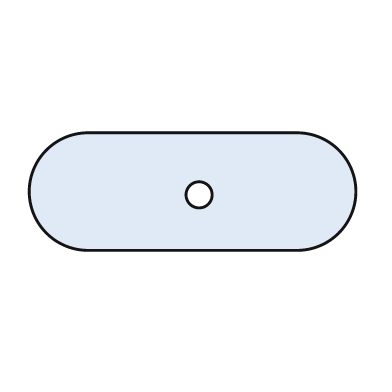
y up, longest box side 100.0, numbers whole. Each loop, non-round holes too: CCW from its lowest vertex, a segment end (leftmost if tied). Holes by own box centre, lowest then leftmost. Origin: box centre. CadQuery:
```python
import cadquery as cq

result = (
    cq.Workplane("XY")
    .moveTo(-32.0, -18.0)
    .lineTo(32.0, -18.0)
    .threePointArc((50.0, 0.0), (32.0, 18.0))
    .lineTo(-32.0, 18.0)
    .threePointArc((-50.0, 0.0), (-32.0, -18.0))
    .close()
    .moveTo(2.0, -1.0)
    .circle(4.0)
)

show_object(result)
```